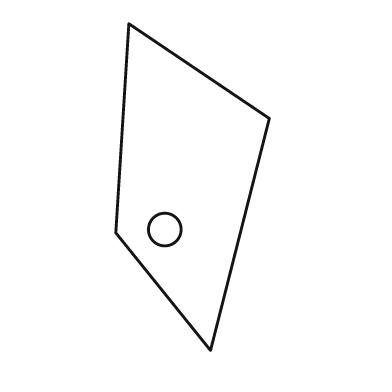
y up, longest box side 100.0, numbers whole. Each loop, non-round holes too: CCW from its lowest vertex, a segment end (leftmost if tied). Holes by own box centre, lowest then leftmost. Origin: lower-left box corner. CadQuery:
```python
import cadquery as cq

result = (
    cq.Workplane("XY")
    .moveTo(29.0, 0.0)
    .lineTo(47.0, 71.0)
    .lineTo(4.0, 100.0)
    .lineTo(0.0, 36.0)
    .close()
    .moveTo(15.0, 37.0)
    .circle(5.0)
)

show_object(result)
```